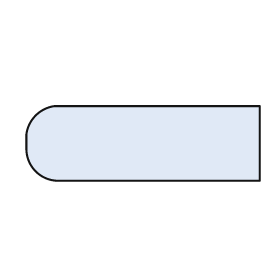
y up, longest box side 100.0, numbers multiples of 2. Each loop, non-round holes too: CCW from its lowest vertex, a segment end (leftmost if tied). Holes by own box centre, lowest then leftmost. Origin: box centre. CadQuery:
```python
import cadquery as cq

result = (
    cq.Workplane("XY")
    .moveTo(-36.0, -16.0)
    .lineTo(50.0, -16.0)
    .lineTo(50.0, 16.0)
    .lineTo(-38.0, 16.0)
    .threePointArc((-46.0, 12.0), (-50.0, 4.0))
    .lineTo(-50.0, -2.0)
    .threePointArc((-46.0, -12.0), (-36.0, -16.0))
    .close()
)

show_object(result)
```